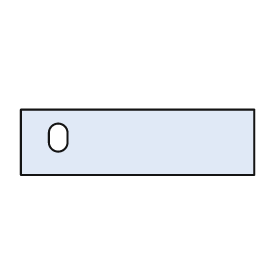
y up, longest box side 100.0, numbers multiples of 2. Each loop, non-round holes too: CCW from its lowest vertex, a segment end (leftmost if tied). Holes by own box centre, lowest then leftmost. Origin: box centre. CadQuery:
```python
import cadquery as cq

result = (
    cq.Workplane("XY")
    .moveTo(-50.0, -14.0)
    .lineTo(50.0, -14.0)
    .lineTo(50.0, 14.0)
    .lineTo(-50.0, 14.0)
    .close()
    .moveTo(-38.0, 0.0)
    .threePointArc((-34.0, -4.0), (-30.0, 0.0))
    .lineTo(-30.0, 4.0)
    .threePointArc((-34.0, 8.0), (-38.0, 4.0))
    .close()
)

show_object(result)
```